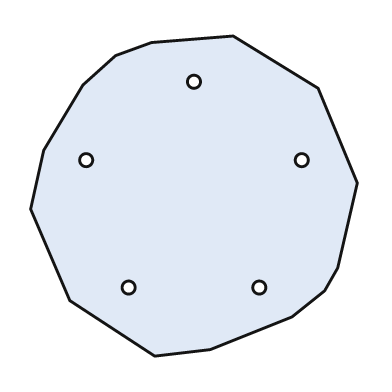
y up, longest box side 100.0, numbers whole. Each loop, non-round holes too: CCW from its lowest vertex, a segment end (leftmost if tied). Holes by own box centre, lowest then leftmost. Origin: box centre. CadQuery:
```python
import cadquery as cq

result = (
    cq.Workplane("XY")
    .moveTo(-12.0, -49.0)
    .lineTo(5.0, -47.0)
    .lineTo(30.0, -37.0)
    .lineTo(40.0, -29.0)
    .lineTo(44.0, -22.0)
    .lineTo(50.0, 4.0)
    .lineTo(38.0, 33.0)
    .lineTo(12.0, 49.0)
    .lineTo(-13.0, 47.0)
    .lineTo(-24.0, 43.0)
    .lineTo(-34.0, 34.0)
    .lineTo(-46.0, 14.0)
    .lineTo(-50.0, -4.0)
    .lineTo(-38.0, -32.0)
    .close()
    .moveTo(-20.0, -28.0)
    .circle(2.0)
    .moveTo(20.0, -28.0)
    .circle(2.0)
    .moveTo(-33.0, 11.0)
    .circle(2.0)
    .moveTo(33.0, 11.0)
    .circle(2.0)
    .moveTo(0.0, 35.0)
    .circle(2.0)
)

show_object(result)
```